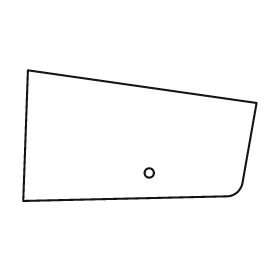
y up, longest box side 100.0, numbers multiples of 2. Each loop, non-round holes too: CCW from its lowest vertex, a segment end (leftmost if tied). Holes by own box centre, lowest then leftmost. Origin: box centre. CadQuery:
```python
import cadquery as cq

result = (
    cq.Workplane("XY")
    .moveTo(-50.0, -28.0)
    .lineTo(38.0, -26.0)
    .threePointArc((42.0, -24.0), (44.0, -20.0))
    .lineTo(50.0, 14.0)
    .lineTo(-48.0, 28.0)
    .close()
    .moveTo(4.0, -16.0)
    .circle(2.0)
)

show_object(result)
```